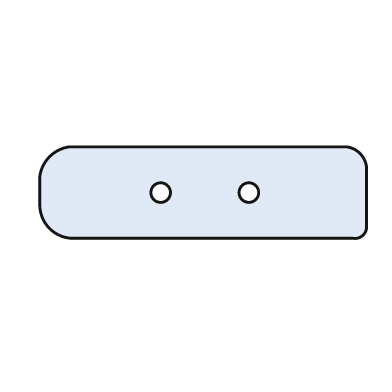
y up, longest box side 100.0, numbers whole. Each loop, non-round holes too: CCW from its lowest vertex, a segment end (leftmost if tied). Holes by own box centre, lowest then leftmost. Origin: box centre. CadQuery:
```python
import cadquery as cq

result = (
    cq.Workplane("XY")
    .moveTo(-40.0, -14.0)
    .lineTo(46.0, -14.0)
    .threePointArc((49.0, -13.0), (50.0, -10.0))
    .lineTo(50.0, 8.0)
    .threePointArc((48.0, 12.0), (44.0, 14.0))
    .lineTo(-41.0, 14.0)
    .threePointArc((-47.0, 11.0), (-50.0, 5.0))
    .lineTo(-50.0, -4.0)
    .threePointArc((-47.0, -11.0), (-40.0, -14.0))
    .close()
    .moveTo(-13.0, 0.0)
    .circle(3.0)
    .moveTo(14.0, 0.0)
    .circle(3.0)
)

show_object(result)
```